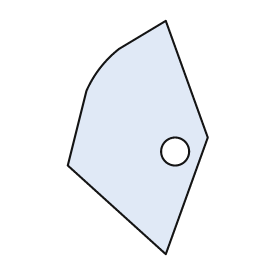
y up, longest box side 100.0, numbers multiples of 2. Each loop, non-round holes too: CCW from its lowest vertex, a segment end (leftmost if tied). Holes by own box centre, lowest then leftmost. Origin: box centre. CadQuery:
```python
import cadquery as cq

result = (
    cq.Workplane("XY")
    .moveTo(12.0, -50.0)
    .lineTo(30.0, 0.0)
    .lineTo(12.0, 50.0)
    .lineTo(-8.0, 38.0)
    .threePointArc((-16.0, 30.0), (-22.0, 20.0))
    .lineTo(-30.0, -12.0)
    .close()
    .moveTo(16.0, -6.0)
    .circle(6.0)
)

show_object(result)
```